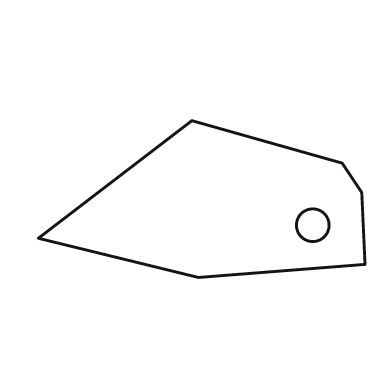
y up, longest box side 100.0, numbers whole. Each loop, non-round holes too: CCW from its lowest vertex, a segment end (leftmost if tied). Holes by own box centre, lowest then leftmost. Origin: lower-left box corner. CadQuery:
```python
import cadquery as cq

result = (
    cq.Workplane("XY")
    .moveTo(49.0, 0.0)
    .lineTo(100.0, 4.0)
    .lineTo(99.0, 26.0)
    .lineTo(93.0, 35.0)
    .lineTo(47.0, 48.0)
    .lineTo(0.0, 12.0)
    .close()
    .moveTo(84.0, 16.0)
    .circle(5.0)
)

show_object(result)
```